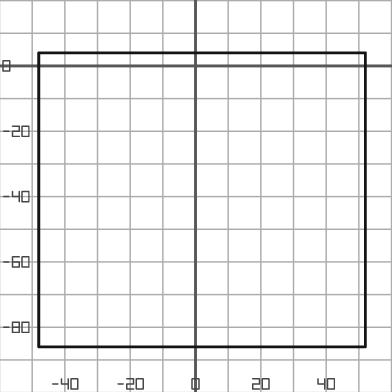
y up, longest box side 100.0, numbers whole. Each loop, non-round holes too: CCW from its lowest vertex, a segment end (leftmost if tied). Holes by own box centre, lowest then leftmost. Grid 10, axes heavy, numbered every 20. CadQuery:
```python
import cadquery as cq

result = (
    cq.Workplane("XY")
    .moveTo(-48.0, -86.0)
    .lineTo(52.0, -86.0)
    .lineTo(52.0, 4.0)
    .lineTo(-48.0, 4.0)
    .close()
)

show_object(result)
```